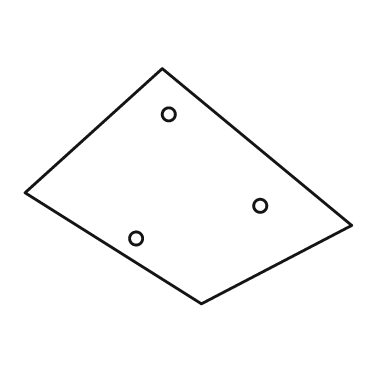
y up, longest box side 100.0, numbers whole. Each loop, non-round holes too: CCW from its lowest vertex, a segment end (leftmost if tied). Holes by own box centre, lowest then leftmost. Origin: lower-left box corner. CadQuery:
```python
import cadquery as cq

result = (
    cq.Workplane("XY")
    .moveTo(54.0, 0.0)
    .lineTo(100.0, 24.0)
    .lineTo(42.0, 72.0)
    .lineTo(0.0, 34.0)
    .close()
    .moveTo(34.0, 20.0)
    .circle(2.0)
    .moveTo(72.0, 30.0)
    .circle(2.0)
    .moveTo(44.0, 58.0)
    .circle(2.0)
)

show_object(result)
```